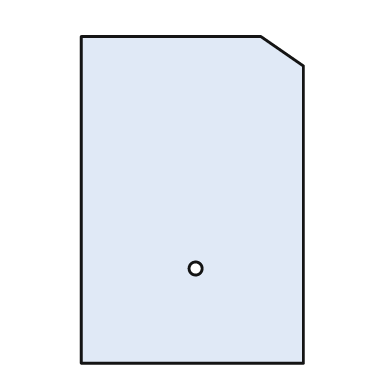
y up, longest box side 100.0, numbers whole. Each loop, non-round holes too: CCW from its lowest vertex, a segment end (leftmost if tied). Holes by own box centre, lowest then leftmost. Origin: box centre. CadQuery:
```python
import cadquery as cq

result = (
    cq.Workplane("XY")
    .moveTo(-34.0, -50.0)
    .lineTo(34.0, -50.0)
    .lineTo(34.0, 41.0)
    .lineTo(21.0, 50.0)
    .lineTo(-34.0, 50.0)
    .close()
    .moveTo(1.0, -21.0)
    .circle(2.0)
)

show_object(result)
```